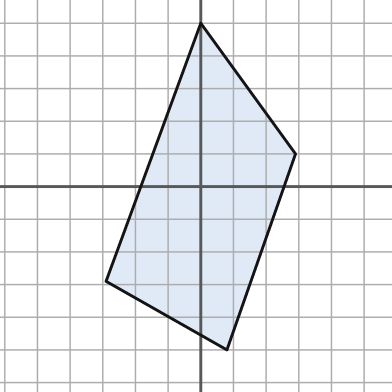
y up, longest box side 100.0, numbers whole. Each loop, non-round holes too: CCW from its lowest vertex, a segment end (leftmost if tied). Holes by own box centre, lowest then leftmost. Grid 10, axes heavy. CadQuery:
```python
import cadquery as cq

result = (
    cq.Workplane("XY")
    .moveTo(8.0, -50.0)
    .lineTo(29.0, 10.0)
    .lineTo(0.0, 50.0)
    .lineTo(-29.0, -29.0)
    .close()
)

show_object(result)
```